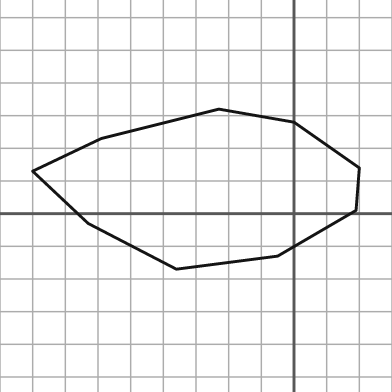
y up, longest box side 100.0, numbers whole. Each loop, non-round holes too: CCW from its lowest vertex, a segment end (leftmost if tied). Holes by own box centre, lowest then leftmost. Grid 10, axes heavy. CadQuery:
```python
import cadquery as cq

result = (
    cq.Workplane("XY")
    .moveTo(-36.0, -17.0)
    .lineTo(-5.0, -13.0)
    .lineTo(19.0, 1.0)
    .lineTo(20.0, 14.0)
    .lineTo(0.0, 28.0)
    .lineTo(-23.0, 32.0)
    .lineTo(-59.0, 23.0)
    .lineTo(-80.0, 13.0)
    .lineTo(-63.0, -3.0)
    .close()
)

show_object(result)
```